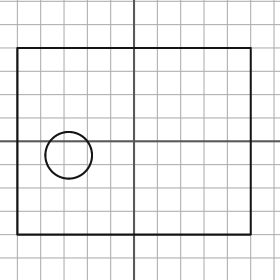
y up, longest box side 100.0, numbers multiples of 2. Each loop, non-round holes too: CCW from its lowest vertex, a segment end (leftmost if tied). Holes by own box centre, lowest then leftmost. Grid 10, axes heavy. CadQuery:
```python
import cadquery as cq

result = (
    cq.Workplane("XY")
    .moveTo(-50.0, -40.0)
    .lineTo(50.0, -40.0)
    .lineTo(50.0, 40.0)
    .lineTo(-50.0, 40.0)
    .close()
    .moveTo(-28.0, -6.0)
    .circle(10.0)
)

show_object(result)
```